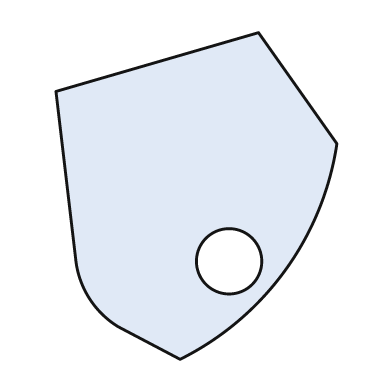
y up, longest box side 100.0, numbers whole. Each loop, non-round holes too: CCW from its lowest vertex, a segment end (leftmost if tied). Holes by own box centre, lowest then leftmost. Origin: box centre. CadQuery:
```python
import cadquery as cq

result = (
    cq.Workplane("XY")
    .moveTo(-5.0, -50.0)
    .threePointArc((27.0, -23.0), (43.0, 16.0))
    .lineTo(19.0, 50.0)
    .lineTo(-43.0, 32.0)
    .lineTo(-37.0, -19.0)
    .threePointArc((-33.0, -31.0), (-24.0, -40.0))
    .close()
    .moveTo(10.0, -20.0)
    .circle(10.0)
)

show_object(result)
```